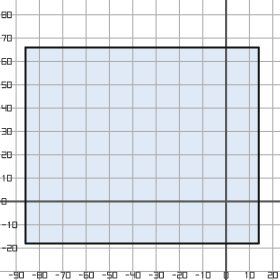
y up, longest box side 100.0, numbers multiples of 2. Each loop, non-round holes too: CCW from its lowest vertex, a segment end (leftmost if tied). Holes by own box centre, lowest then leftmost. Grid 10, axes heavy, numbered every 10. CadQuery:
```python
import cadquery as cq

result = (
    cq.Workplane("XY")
    .moveTo(-86.0, -18.0)
    .lineTo(14.0, -18.0)
    .lineTo(14.0, 66.0)
    .lineTo(-86.0, 66.0)
    .close()
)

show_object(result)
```